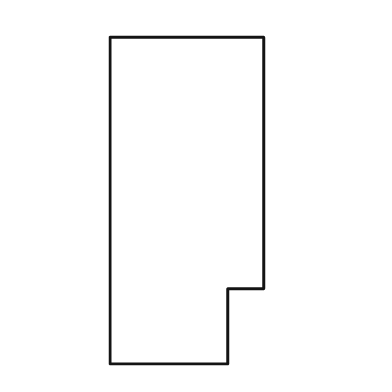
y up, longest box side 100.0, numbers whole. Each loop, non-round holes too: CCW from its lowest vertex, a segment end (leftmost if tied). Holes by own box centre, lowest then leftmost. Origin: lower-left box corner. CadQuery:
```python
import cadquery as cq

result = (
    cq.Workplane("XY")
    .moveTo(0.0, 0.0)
    .lineTo(36.0, 0.0)
    .lineTo(36.0, 23.0)
    .lineTo(47.0, 23.0)
    .lineTo(47.0, 100.0)
    .lineTo(0.0, 100.0)
    .close()
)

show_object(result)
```